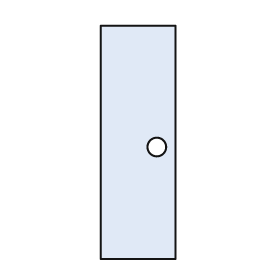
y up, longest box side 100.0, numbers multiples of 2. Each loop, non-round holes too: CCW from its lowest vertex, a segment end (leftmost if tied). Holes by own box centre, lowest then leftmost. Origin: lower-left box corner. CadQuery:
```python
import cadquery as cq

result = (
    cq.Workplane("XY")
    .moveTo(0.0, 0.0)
    .lineTo(32.0, 0.0)
    .lineTo(32.0, 100.0)
    .lineTo(0.0, 100.0)
    .close()
    .moveTo(24.0, 48.0)
    .circle(4.0)
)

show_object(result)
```